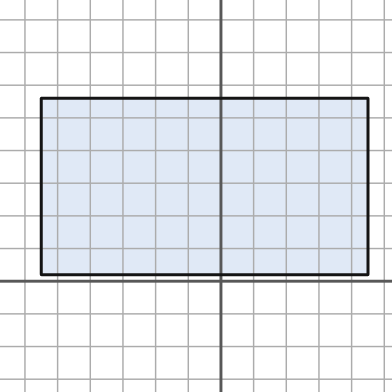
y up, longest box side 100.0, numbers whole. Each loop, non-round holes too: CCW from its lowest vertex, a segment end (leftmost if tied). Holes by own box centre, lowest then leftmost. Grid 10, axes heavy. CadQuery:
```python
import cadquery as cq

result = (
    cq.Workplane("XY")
    .moveTo(-55.0, 2.0)
    .lineTo(45.0, 2.0)
    .lineTo(45.0, 56.0)
    .lineTo(-55.0, 56.0)
    .close()
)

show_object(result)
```